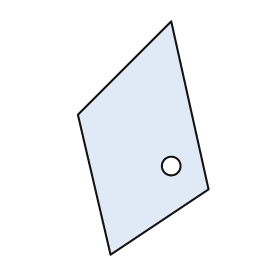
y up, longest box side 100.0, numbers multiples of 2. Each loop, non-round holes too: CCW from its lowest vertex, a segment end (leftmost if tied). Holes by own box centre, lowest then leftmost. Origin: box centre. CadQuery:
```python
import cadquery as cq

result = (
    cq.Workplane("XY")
    .moveTo(-14.0, -50.0)
    .lineTo(28.0, -22.0)
    .lineTo(12.0, 50.0)
    .lineTo(-28.0, 10.0)
    .close()
    .moveTo(12.0, -12.0)
    .circle(4.0)
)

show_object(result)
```